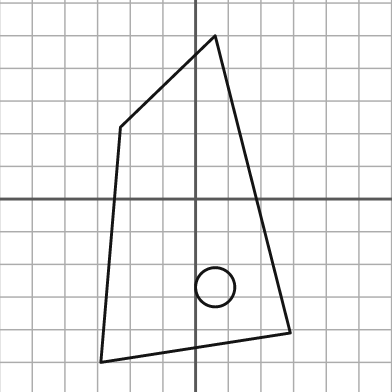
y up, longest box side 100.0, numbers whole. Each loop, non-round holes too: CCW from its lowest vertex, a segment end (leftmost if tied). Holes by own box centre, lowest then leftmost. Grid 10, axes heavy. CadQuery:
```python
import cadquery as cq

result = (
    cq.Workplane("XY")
    .moveTo(-29.0, -50.0)
    .lineTo(29.0, -41.0)
    .lineTo(6.0, 50.0)
    .lineTo(-23.0, 22.0)
    .close()
    .moveTo(6.0, -27.0)
    .circle(6.0)
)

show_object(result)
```